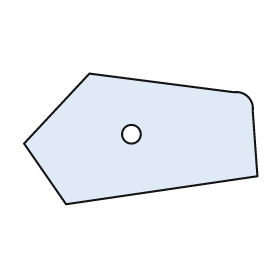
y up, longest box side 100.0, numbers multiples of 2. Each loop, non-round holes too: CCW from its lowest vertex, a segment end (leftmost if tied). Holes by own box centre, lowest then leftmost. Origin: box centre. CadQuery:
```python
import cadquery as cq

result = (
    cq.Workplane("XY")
    .moveTo(-32.0, -28.0)
    .lineTo(50.0, -16.0)
    .lineTo(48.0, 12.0)
    .threePointArc((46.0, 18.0), (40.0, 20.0))
    .lineTo(-22.0, 28.0)
    .lineTo(-50.0, -2.0)
    .close()
    .moveTo(-4.0, 2.0)
    .circle(4.0)
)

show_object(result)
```